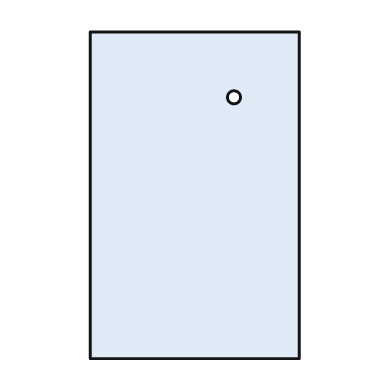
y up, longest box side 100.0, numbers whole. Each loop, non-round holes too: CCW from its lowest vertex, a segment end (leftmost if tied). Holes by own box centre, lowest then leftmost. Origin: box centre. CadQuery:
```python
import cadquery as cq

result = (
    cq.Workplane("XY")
    .moveTo(-32.0, -50.0)
    .lineTo(32.0, -50.0)
    .lineTo(32.0, 50.0)
    .lineTo(-32.0, 50.0)
    .close()
    .moveTo(12.0, 30.0)
    .circle(2.0)
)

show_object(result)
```